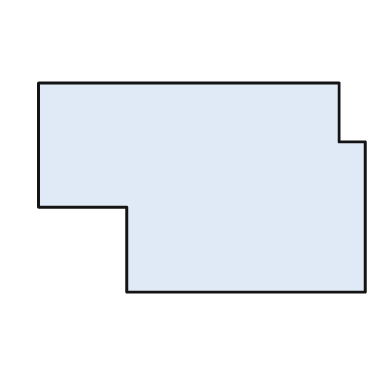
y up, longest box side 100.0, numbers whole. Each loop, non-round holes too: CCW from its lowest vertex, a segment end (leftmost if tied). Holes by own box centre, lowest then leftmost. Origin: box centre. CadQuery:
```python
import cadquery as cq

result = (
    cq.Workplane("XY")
    .moveTo(-23.0, -32.0)
    .lineTo(50.0, -32.0)
    .lineTo(50.0, 14.0)
    .lineTo(42.0, 14.0)
    .lineTo(42.0, 32.0)
    .lineTo(-50.0, 32.0)
    .lineTo(-50.0, -6.0)
    .lineTo(-23.0, -6.0)
    .close()
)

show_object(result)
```